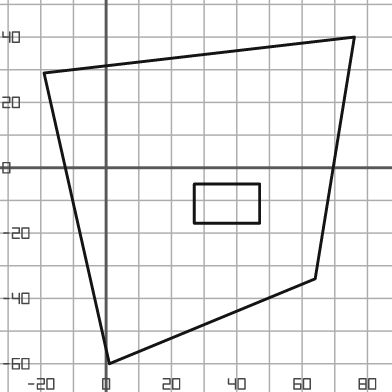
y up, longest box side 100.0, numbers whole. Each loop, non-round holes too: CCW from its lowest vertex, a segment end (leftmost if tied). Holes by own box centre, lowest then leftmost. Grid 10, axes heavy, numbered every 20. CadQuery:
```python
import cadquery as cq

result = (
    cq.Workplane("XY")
    .moveTo(1.0, -60.0)
    .lineTo(64.0, -34.0)
    .lineTo(76.0, 40.0)
    .lineTo(-19.0, 29.0)
    .close()
    .moveTo(27.0, -17.0)
    .lineTo(47.0, -17.0)
    .lineTo(47.0, -5.0)
    .lineTo(27.0, -5.0)
    .close()
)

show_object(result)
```